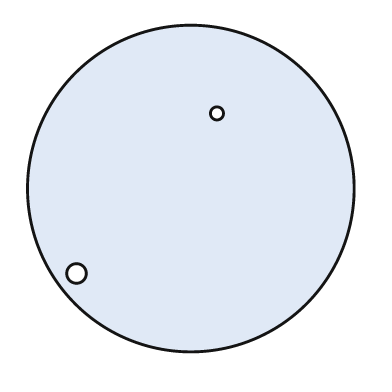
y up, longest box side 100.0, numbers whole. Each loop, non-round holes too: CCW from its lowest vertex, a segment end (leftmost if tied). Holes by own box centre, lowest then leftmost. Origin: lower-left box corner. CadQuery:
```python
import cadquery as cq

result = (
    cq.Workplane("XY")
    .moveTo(50.0, 50.0)
    .circle(50.0)
    .moveTo(15.0, 24.0)
    .circle(3.0)
    .moveTo(58.0, 73.0)
    .circle(2.0)
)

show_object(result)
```